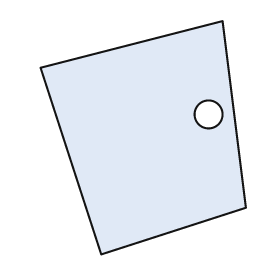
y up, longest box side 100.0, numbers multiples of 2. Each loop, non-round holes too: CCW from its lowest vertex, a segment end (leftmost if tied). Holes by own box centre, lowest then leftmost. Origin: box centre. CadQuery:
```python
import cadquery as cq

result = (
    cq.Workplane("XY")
    .moveTo(-18.0, -50.0)
    .lineTo(44.0, -30.0)
    .lineTo(34.0, 50.0)
    .lineTo(-44.0, 30.0)
    .close()
    .moveTo(28.0, 10.0)
    .circle(6.0)
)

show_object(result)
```